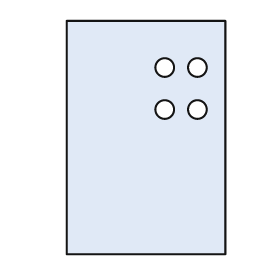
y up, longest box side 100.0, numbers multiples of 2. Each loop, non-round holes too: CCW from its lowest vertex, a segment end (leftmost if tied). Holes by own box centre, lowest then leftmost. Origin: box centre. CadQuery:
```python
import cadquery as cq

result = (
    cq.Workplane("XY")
    .moveTo(-34.0, -50.0)
    .lineTo(34.0, -50.0)
    .lineTo(34.0, 50.0)
    .lineTo(-34.0, 50.0)
    .close()
    .moveTo(8.0, 12.0)
    .circle(4.0)
    .moveTo(22.0, 12.0)
    .circle(4.0)
    .moveTo(8.0, 30.0)
    .circle(4.0)
    .moveTo(22.0, 30.0)
    .circle(4.0)
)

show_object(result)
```